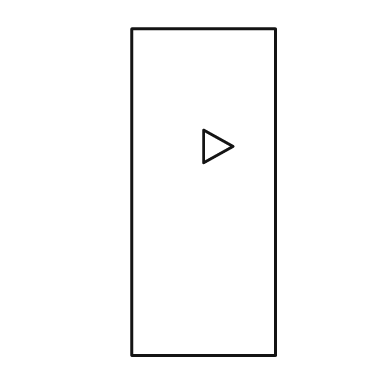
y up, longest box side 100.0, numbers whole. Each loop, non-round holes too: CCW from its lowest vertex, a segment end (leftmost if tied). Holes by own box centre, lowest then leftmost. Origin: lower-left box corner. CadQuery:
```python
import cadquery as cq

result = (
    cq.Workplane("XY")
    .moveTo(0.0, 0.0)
    .lineTo(44.0, 0.0)
    .lineTo(44.0, 100.0)
    .lineTo(0.0, 100.0)
    .close()
    .moveTo(22.0, 59.0)
    .lineTo(31.0, 64.0)
    .lineTo(22.0, 69.0)
    .close()
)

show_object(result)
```